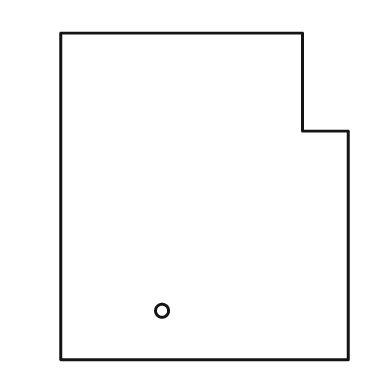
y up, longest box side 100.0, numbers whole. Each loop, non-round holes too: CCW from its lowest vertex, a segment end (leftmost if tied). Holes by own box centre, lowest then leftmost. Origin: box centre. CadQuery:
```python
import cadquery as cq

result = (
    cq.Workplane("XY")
    .moveTo(-44.0, -50.0)
    .lineTo(44.0, -50.0)
    .lineTo(44.0, 20.0)
    .lineTo(30.0, 20.0)
    .lineTo(30.0, 50.0)
    .lineTo(-44.0, 50.0)
    .close()
    .moveTo(-13.0, -35.0)
    .circle(2.0)
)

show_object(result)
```